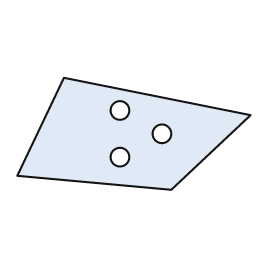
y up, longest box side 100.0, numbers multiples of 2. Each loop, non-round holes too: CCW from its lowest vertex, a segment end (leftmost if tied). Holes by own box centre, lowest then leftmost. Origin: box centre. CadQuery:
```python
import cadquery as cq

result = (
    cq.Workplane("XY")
    .moveTo(16.0, -24.0)
    .lineTo(50.0, 8.0)
    .lineTo(-30.0, 24.0)
    .lineTo(-50.0, -18.0)
    .close()
    .moveTo(-6.0, -10.0)
    .circle(4.0)
    .moveTo(12.0, 0.0)
    .circle(4.0)
    .moveTo(-6.0, 10.0)
    .circle(4.0)
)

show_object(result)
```